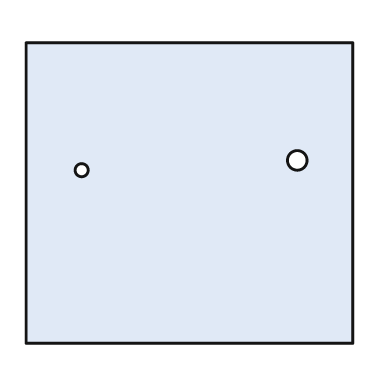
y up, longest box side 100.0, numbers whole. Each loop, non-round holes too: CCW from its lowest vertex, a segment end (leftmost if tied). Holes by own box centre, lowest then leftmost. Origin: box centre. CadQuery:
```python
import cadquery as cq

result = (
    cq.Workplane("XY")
    .moveTo(-50.0, -46.0)
    .lineTo(50.0, -46.0)
    .lineTo(50.0, 46.0)
    .lineTo(-50.0, 46.0)
    .close()
    .moveTo(-33.0, 7.0)
    .circle(2.0)
    .moveTo(33.0, 10.0)
    .circle(3.0)
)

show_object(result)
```